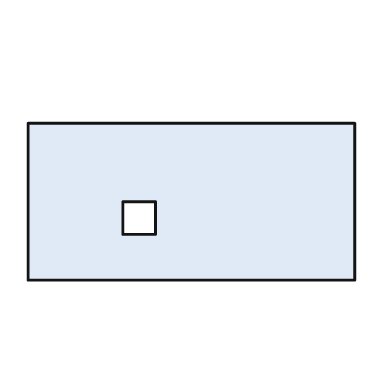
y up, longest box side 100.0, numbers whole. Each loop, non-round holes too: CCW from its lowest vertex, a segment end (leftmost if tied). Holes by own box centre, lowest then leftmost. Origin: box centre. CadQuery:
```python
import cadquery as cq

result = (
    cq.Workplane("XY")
    .moveTo(-50.0, -24.0)
    .lineTo(50.0, -24.0)
    .lineTo(50.0, 24.0)
    .lineTo(-50.0, 24.0)
    .close()
    .moveTo(-21.0, -10.0)
    .lineTo(-11.0, -10.0)
    .lineTo(-11.0, 0.0)
    .lineTo(-21.0, 0.0)
    .close()
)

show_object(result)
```